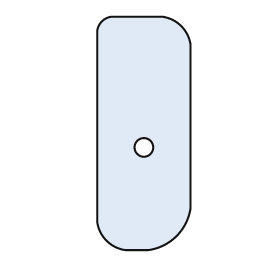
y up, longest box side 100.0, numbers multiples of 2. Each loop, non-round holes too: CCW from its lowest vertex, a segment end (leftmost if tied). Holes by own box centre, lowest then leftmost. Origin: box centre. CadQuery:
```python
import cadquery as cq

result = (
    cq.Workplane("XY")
    .moveTo(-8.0, -50.0)
    .lineTo(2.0, -50.0)
    .threePointArc((14.0, -44.0), (20.0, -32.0))
    .lineTo(20.0, 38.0)
    .threePointArc((16.0, 46.0), (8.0, 50.0))
    .lineTo(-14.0, 50.0)
    .threePointArc((-18.0, 48.0), (-20.0, 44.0))
    .lineTo(-20.0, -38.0)
    .threePointArc((-16.0, -46.0), (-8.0, -50.0))
    .close()
    .moveTo(0.0, -6.0)
    .circle(4.0)
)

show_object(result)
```